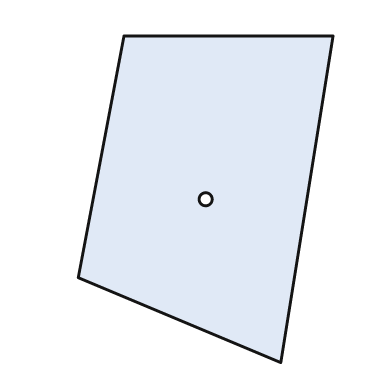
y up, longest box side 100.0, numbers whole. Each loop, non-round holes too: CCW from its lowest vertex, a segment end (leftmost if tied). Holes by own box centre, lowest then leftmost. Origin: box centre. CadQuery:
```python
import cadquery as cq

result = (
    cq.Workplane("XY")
    .moveTo(23.0, -50.0)
    .lineTo(39.0, 50.0)
    .lineTo(-25.0, 50.0)
    .lineTo(-39.0, -24.0)
    .close()
    .moveTo(0.0, 0.0)
    .circle(2.0)
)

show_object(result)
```